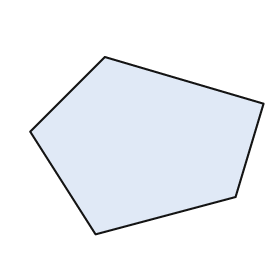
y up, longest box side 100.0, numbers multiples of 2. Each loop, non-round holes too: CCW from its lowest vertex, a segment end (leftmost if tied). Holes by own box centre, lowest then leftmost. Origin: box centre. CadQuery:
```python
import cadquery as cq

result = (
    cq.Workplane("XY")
    .moveTo(-22.0, -38.0)
    .lineTo(38.0, -22.0)
    .lineTo(50.0, 18.0)
    .lineTo(-18.0, 38.0)
    .lineTo(-50.0, 6.0)
    .close()
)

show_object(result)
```